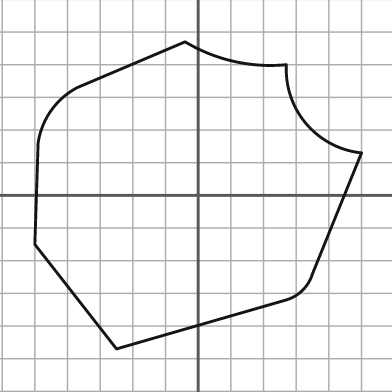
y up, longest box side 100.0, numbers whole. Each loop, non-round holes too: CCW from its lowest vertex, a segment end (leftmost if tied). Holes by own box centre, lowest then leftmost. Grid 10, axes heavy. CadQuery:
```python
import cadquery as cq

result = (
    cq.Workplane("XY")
    .moveTo(-25.0, -47.0)
    .lineTo(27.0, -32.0)
    .threePointArc((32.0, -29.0), (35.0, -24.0))
    .lineTo(50.0, 13.0)
    .threePointArc((33.0, 22.0), (27.0, 40.0))
    .threePointArc((11.0, 41.0), (-4.0, 47.0))
    .lineTo(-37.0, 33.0)
    .threePointArc((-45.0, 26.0), (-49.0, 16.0))
    .lineTo(-50.0, -15.0)
    .close()
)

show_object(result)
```